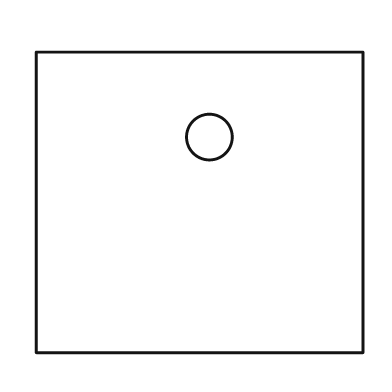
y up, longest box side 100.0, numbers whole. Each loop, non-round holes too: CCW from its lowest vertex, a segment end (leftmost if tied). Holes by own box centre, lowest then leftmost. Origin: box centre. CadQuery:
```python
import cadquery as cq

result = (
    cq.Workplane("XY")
    .moveTo(-50.0, -46.0)
    .lineTo(50.0, -46.0)
    .lineTo(50.0, 46.0)
    .lineTo(-50.0, 46.0)
    .close()
    .moveTo(3.0, 20.0)
    .circle(7.0)
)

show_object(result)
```